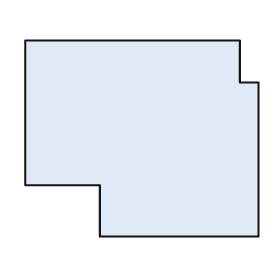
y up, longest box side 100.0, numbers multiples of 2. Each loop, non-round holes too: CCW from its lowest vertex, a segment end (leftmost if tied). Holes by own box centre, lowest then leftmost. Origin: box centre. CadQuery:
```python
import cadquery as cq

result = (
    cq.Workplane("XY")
    .moveTo(-18.0, -42.0)
    .lineTo(50.0, -42.0)
    .lineTo(50.0, 24.0)
    .lineTo(42.0, 24.0)
    .lineTo(42.0, 42.0)
    .lineTo(-50.0, 42.0)
    .lineTo(-50.0, -20.0)
    .lineTo(-18.0, -20.0)
    .close()
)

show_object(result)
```